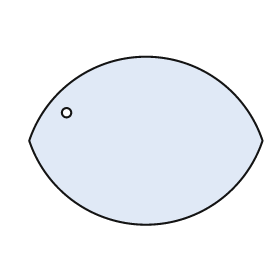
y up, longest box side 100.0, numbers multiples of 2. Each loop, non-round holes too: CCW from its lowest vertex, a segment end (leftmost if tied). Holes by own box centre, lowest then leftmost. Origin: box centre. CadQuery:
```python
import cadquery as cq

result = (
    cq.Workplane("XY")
    .moveTo(-50.0, 0.0)
    .threePointArc((0.0, -36.0), (50.0, 0.0))
    .threePointArc((0.0, 36.0), (-50.0, 0.0))
    .close()
    .moveTo(-34.0, 12.0)
    .circle(2.0)
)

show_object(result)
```